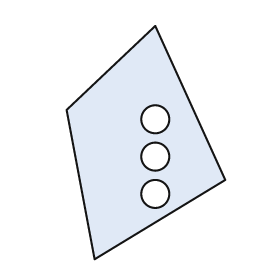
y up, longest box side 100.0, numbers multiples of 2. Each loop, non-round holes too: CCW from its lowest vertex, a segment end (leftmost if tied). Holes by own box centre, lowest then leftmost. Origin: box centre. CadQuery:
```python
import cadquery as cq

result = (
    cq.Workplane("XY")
    .moveTo(-22.0, -50.0)
    .lineTo(34.0, -16.0)
    .lineTo(4.0, 50.0)
    .lineTo(-34.0, 14.0)
    .close()
    .moveTo(4.0, -22.0)
    .circle(6.0)
    .moveTo(4.0, -6.0)
    .circle(6.0)
    .moveTo(4.0, 10.0)
    .circle(6.0)
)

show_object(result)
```